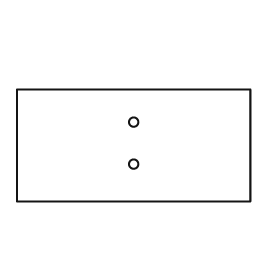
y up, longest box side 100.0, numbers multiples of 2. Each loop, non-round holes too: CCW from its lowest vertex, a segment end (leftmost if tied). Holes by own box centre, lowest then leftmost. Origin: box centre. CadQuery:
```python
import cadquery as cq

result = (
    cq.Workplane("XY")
    .moveTo(-50.0, -24.0)
    .lineTo(50.0, -24.0)
    .lineTo(50.0, 24.0)
    .lineTo(-50.0, 24.0)
    .close()
    .moveTo(0.0, -8.0)
    .circle(2.0)
    .moveTo(0.0, 10.0)
    .circle(2.0)
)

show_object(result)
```